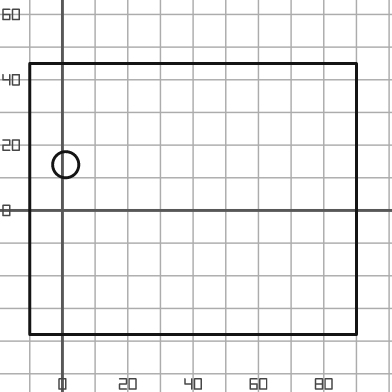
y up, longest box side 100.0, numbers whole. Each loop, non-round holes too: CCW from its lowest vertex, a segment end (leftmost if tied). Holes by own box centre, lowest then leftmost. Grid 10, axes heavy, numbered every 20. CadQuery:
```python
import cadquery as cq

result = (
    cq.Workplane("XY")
    .moveTo(-10.0, -38.0)
    .lineTo(90.0, -38.0)
    .lineTo(90.0, 45.0)
    .lineTo(-10.0, 45.0)
    .close()
    .moveTo(1.0, 14.0)
    .circle(4.0)
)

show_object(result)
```